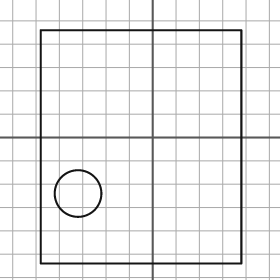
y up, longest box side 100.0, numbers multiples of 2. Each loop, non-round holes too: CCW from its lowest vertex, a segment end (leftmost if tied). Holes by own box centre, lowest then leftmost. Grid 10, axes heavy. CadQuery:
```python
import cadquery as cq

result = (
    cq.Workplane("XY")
    .moveTo(-48.0, -54.0)
    .lineTo(38.0, -54.0)
    .lineTo(38.0, 46.0)
    .lineTo(-48.0, 46.0)
    .close()
    .moveTo(-32.0, -24.0)
    .circle(10.0)
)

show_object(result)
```